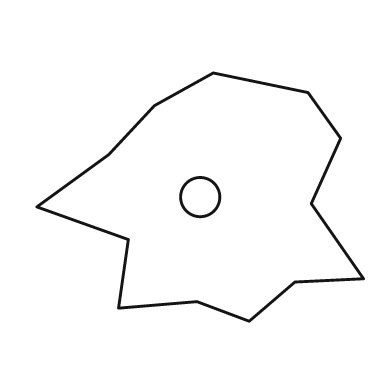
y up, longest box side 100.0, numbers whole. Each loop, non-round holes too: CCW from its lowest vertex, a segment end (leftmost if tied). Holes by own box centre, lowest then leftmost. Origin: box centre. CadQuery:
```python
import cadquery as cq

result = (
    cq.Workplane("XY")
    .moveTo(15.0, -38.0)
    .lineTo(29.0, -26.0)
    .lineTo(50.0, -25.0)
    .lineTo(34.0, -2.0)
    .lineTo(43.0, 18.0)
    .lineTo(33.0, 32.0)
    .lineTo(4.0, 38.0)
    .lineTo(-14.0, 28.0)
    .lineTo(-28.0, 13.0)
    .lineTo(-50.0, -3.0)
    .lineTo(-22.0, -13.0)
    .lineTo(-25.0, -34.0)
    .lineTo(-1.0, -32.0)
    .close()
    .moveTo(0.0, 0.0)
    .circle(6.0)
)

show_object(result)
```